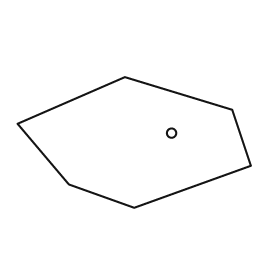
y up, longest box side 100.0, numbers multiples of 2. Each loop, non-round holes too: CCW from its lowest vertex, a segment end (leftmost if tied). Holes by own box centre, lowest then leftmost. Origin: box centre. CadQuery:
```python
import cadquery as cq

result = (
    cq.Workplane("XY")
    .moveTo(0.0, -28.0)
    .lineTo(50.0, -10.0)
    .lineTo(42.0, 14.0)
    .lineTo(-4.0, 28.0)
    .lineTo(-50.0, 8.0)
    .lineTo(-28.0, -18.0)
    .close()
    .moveTo(16.0, 4.0)
    .circle(2.0)
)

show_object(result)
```